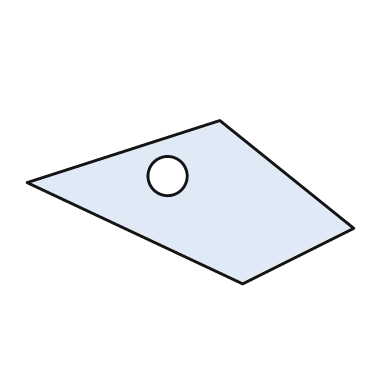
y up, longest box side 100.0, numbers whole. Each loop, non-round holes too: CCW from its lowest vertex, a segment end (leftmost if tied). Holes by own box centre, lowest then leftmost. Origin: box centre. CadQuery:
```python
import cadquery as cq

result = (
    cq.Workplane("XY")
    .moveTo(16.0, -25.0)
    .lineTo(50.0, -8.0)
    .lineTo(9.0, 25.0)
    .lineTo(-50.0, 6.0)
    .close()
    .moveTo(-7.0, 8.0)
    .circle(6.0)
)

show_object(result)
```